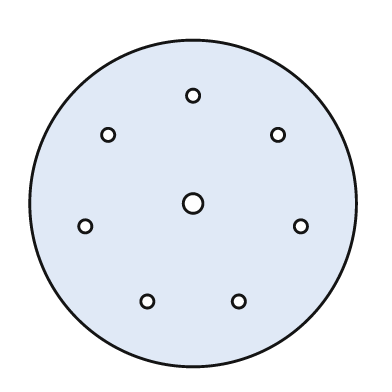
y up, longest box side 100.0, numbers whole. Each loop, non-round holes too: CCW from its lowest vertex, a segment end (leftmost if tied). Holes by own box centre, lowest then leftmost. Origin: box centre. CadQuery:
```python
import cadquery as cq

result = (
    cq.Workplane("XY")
    .moveTo(0.0, 0.0)
    .circle(50.0)
    .moveTo(-14.0, -30.0)
    .circle(2.0)
    .moveTo(14.0, -30.0)
    .circle(2.0)
    .moveTo(-33.0, -7.0)
    .circle(2.0)
    .moveTo(33.0, -7.0)
    .circle(2.0)
    .moveTo(0.0, 0.0)
    .circle(3.0)
    .moveTo(-26.0, 21.0)
    .circle(2.0)
    .moveTo(26.0, 21.0)
    .circle(2.0)
    .moveTo(0.0, 33.0)
    .circle(2.0)
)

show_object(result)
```